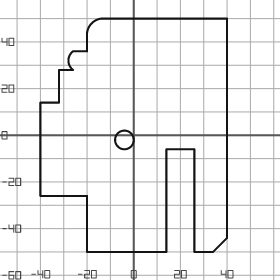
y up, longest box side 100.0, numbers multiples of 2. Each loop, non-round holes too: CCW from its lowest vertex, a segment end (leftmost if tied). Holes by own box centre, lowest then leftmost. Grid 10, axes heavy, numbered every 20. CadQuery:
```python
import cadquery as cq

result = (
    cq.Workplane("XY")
    .moveTo(-20.0, -50.0)
    .lineTo(14.0, -50.0)
    .lineTo(14.0, -6.0)
    .lineTo(26.0, -6.0)
    .lineTo(26.0, -50.0)
    .lineTo(34.0, -50.0)
    .lineTo(40.0, -44.0)
    .lineTo(40.0, 50.0)
    .lineTo(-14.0, 50.0)
    .threePointArc((-18.0, 48.0), (-20.0, 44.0))
    .lineTo(-20.0, 36.0)
    .lineTo(-26.0, 36.0)
    .threePointArc((-28.0, 32.0), (-26.0, 28.0))
    .lineTo(-32.0, 28.0)
    .lineTo(-32.0, 14.0)
    .lineTo(-40.0, 14.0)
    .lineTo(-40.0, -26.0)
    .lineTo(-20.0, -26.0)
    .close()
    .moveTo(-4.0, -2.0)
    .circle(4.0)
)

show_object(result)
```